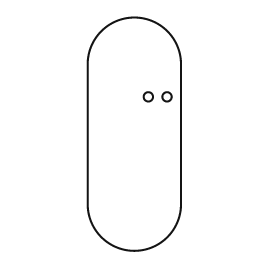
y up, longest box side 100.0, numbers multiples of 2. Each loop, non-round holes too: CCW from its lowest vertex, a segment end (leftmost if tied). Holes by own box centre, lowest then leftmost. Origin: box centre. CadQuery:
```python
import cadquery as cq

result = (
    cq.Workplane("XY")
    .moveTo(-20.0, -30.0)
    .threePointArc((0.0, -50.0), (20.0, -30.0))
    .lineTo(20.0, 30.0)
    .threePointArc((0.0, 50.0), (-20.0, 30.0))
    .close()
    .moveTo(6.0, 16.0)
    .circle(2.0)
    .moveTo(14.0, 16.0)
    .circle(2.0)
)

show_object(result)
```